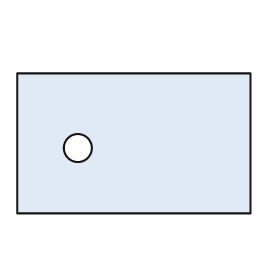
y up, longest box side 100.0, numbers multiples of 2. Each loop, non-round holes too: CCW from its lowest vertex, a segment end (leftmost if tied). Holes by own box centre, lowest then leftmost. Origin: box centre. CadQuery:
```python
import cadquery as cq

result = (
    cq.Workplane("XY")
    .moveTo(-50.0, -30.0)
    .lineTo(50.0, -30.0)
    .lineTo(50.0, 30.0)
    .lineTo(-50.0, 30.0)
    .close()
    .moveTo(-24.0, -2.0)
    .circle(6.0)
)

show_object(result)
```